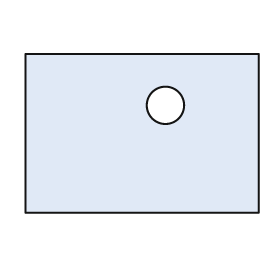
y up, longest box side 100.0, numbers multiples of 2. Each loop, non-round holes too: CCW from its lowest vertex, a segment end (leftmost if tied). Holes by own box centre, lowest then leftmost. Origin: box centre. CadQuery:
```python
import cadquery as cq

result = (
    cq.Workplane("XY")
    .moveTo(-50.0, -34.0)
    .lineTo(50.0, -34.0)
    .lineTo(50.0, 34.0)
    .lineTo(-50.0, 34.0)
    .close()
    .moveTo(10.0, 12.0)
    .circle(8.0)
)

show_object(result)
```